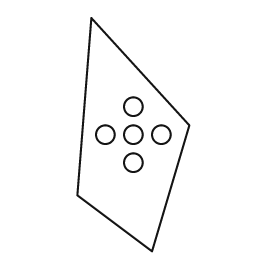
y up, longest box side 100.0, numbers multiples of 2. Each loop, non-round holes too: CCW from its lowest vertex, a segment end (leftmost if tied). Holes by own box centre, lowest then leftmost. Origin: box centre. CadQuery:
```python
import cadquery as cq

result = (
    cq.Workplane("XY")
    .moveTo(8.0, -50.0)
    .lineTo(24.0, 4.0)
    .lineTo(-18.0, 50.0)
    .lineTo(-24.0, -26.0)
    .close()
    .moveTo(0.0, -12.0)
    .circle(4.0)
    .moveTo(-12.0, 0.0)
    .circle(4.0)
    .moveTo(0.0, 0.0)
    .circle(4.0)
    .moveTo(12.0, 0.0)
    .circle(4.0)
    .moveTo(0.0, 12.0)
    .circle(4.0)
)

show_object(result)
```